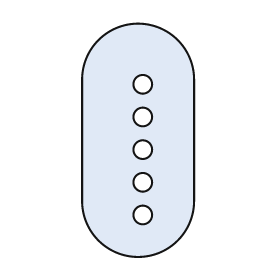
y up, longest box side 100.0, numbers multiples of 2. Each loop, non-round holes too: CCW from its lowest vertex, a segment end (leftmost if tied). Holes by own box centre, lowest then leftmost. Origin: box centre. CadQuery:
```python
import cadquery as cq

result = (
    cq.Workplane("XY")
    .moveTo(-24.0, -26.0)
    .threePointArc((0.0, -50.0), (24.0, -26.0))
    .lineTo(24.0, 26.0)
    .threePointArc((0.0, 50.0), (-24.0, 26.0))
    .close()
    .moveTo(2.0, -32.0)
    .circle(4.0)
    .moveTo(2.0, -18.0)
    .circle(4.0)
    .moveTo(2.0, -4.0)
    .circle(4.0)
    .moveTo(2.0, 10.0)
    .circle(4.0)
    .moveTo(2.0, 24.0)
    .circle(4.0)
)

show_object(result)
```